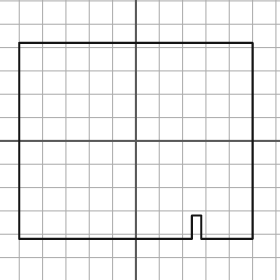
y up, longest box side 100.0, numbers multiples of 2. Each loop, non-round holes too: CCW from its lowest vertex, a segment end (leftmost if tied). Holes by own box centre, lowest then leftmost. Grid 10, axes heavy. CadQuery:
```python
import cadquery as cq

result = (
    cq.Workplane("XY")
    .moveTo(-50.0, -42.0)
    .lineTo(24.0, -42.0)
    .lineTo(24.0, -32.0)
    .lineTo(28.0, -32.0)
    .lineTo(28.0, -42.0)
    .lineTo(50.0, -42.0)
    .lineTo(50.0, 42.0)
    .lineTo(-50.0, 42.0)
    .close()
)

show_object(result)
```